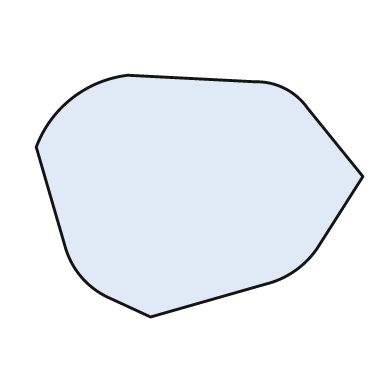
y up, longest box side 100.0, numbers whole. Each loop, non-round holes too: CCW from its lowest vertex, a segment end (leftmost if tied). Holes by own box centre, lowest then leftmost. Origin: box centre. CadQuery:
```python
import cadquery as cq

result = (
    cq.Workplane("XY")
    .moveTo(-15.0, -37.0)
    .lineTo(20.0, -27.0)
    .threePointArc((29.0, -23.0), (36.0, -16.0))
    .lineTo(50.0, 6.0)
    .lineTo(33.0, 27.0)
    .threePointArc((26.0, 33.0), (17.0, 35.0))
    .lineTo(-22.0, 37.0)
    .threePointArc((-39.0, 30.0), (-50.0, 15.0))
    .lineTo(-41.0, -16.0)
    .threePointArc((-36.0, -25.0), (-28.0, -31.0))
    .close()
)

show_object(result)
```